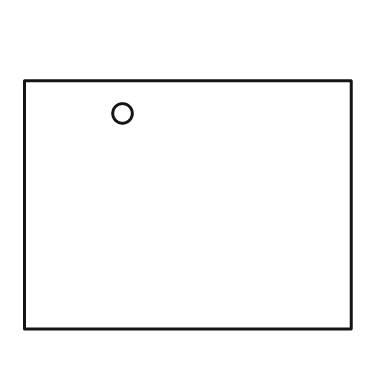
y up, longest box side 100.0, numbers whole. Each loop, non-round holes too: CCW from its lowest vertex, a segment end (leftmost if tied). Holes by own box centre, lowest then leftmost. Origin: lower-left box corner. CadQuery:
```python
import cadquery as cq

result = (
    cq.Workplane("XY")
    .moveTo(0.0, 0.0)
    .lineTo(100.0, 0.0)
    .lineTo(100.0, 76.0)
    .lineTo(0.0, 76.0)
    .close()
    .moveTo(30.0, 66.0)
    .circle(3.0)
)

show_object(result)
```